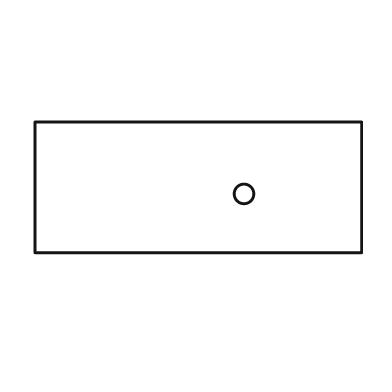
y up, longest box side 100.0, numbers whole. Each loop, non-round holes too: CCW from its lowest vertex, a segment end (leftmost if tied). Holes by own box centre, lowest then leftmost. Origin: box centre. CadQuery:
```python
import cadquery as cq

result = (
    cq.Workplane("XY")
    .moveTo(-50.0, -20.0)
    .lineTo(50.0, -20.0)
    .lineTo(50.0, 20.0)
    .lineTo(-50.0, 20.0)
    .close()
    .moveTo(14.0, -2.0)
    .circle(3.0)
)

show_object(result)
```